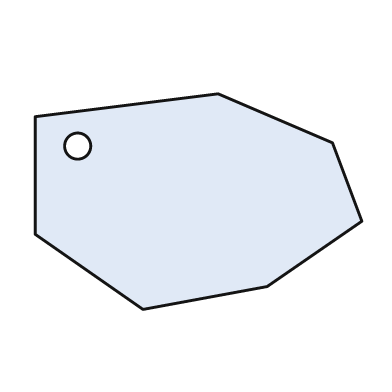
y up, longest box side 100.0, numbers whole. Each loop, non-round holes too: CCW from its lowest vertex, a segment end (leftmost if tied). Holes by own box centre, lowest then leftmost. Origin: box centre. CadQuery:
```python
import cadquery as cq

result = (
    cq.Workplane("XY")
    .moveTo(-17.0, -33.0)
    .lineTo(21.0, -26.0)
    .lineTo(50.0, -6.0)
    .lineTo(41.0, 18.0)
    .lineTo(6.0, 33.0)
    .lineTo(-50.0, 26.0)
    .lineTo(-50.0, -10.0)
    .close()
    .moveTo(-37.0, 17.0)
    .circle(4.0)
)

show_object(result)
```